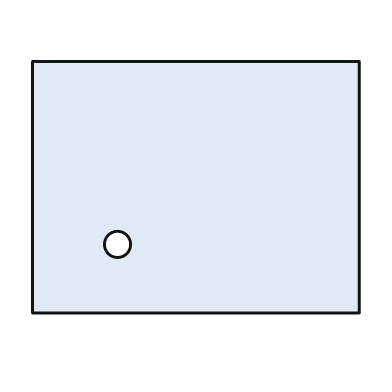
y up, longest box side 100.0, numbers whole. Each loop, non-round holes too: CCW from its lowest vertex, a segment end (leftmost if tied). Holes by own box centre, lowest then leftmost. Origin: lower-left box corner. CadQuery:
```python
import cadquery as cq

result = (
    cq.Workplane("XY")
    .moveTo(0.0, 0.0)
    .lineTo(100.0, 0.0)
    .lineTo(100.0, 77.0)
    .lineTo(0.0, 77.0)
    .close()
    .moveTo(26.0, 21.0)
    .circle(4.0)
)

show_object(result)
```